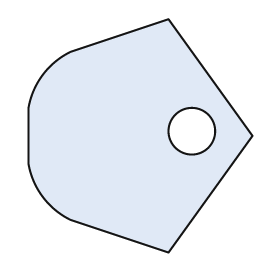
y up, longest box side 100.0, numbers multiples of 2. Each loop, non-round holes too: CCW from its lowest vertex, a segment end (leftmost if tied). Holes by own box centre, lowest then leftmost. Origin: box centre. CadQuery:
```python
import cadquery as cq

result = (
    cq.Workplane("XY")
    .moveTo(12.0, -50.0)
    .lineTo(48.0, 0.0)
    .lineTo(12.0, 50.0)
    .lineTo(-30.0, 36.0)
    .threePointArc((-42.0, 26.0), (-48.0, 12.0))
    .lineTo(-48.0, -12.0)
    .threePointArc((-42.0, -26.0), (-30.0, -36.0))
    .close()
    .moveTo(22.0, 2.0)
    .circle(10.0)
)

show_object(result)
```